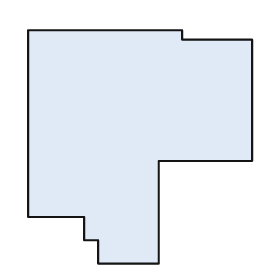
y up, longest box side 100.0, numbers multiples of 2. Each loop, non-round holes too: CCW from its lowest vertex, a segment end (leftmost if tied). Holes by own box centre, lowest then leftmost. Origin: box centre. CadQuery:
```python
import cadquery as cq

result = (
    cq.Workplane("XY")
    .moveTo(-18.0, -50.0)
    .lineTo(8.0, -50.0)
    .lineTo(8.0, -6.0)
    .lineTo(48.0, -6.0)
    .lineTo(48.0, 46.0)
    .lineTo(18.0, 46.0)
    .lineTo(18.0, 50.0)
    .lineTo(-48.0, 50.0)
    .lineTo(-48.0, -30.0)
    .lineTo(-24.0, -30.0)
    .lineTo(-24.0, -40.0)
    .lineTo(-18.0, -40.0)
    .close()
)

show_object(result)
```